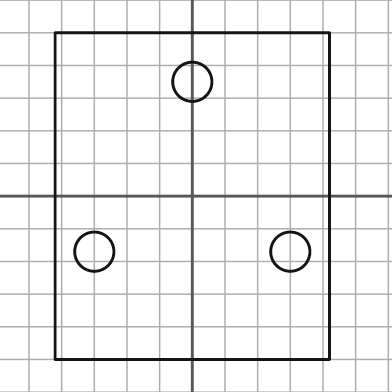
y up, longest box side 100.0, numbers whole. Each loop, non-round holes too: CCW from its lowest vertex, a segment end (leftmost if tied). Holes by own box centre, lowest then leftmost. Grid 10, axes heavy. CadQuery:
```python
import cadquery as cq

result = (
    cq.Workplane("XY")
    .moveTo(-42.0, -50.0)
    .lineTo(42.0, -50.0)
    .lineTo(42.0, 50.0)
    .lineTo(-42.0, 50.0)
    .close()
    .moveTo(-30.0, -17.0)
    .circle(6.0)
    .moveTo(30.0, -17.0)
    .circle(6.0)
    .moveTo(0.0, 35.0)
    .circle(6.0)
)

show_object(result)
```